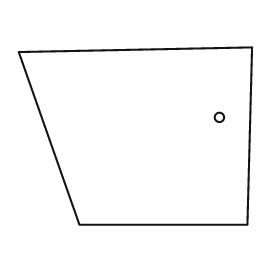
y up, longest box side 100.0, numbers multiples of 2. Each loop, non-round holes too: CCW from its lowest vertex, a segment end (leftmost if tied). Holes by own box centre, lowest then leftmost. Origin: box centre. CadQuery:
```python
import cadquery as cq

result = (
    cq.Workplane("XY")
    .moveTo(-24.0, -38.0)
    .lineTo(48.0, -38.0)
    .lineTo(50.0, 38.0)
    .lineTo(-50.0, 36.0)
    .close()
    .moveTo(36.0, 8.0)
    .circle(2.0)
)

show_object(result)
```